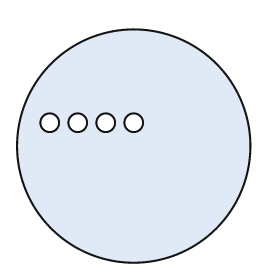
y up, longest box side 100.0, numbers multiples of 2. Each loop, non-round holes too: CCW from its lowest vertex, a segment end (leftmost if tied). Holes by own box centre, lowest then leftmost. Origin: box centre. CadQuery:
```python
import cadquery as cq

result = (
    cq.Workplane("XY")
    .moveTo(0.0, 0.0)
    .circle(50.0)
    .moveTo(-36.0, 10.0)
    .circle(4.0)
    .moveTo(-24.0, 10.0)
    .circle(4.0)
    .moveTo(-12.0, 10.0)
    .circle(4.0)
    .moveTo(0.0, 10.0)
    .circle(4.0)
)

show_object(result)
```